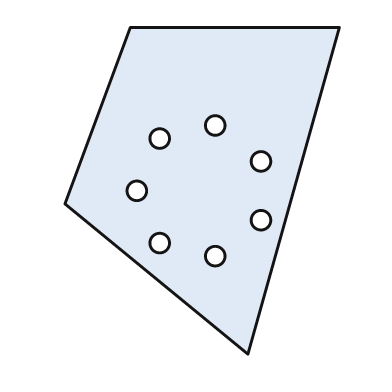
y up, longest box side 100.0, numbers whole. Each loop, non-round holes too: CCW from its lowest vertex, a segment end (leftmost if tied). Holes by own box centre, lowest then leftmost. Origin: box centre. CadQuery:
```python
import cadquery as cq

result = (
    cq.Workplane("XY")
    .moveTo(14.0, -50.0)
    .lineTo(42.0, 50.0)
    .lineTo(-22.0, 50.0)
    .lineTo(-42.0, -4.0)
    .close()
    .moveTo(4.0, -20.0)
    .circle(3.0)
    .moveTo(-13.0, -16.0)
    .circle(3.0)
    .moveTo(18.0, -9.0)
    .circle(3.0)
    .moveTo(-20.0, 0.0)
    .circle(3.0)
    .moveTo(18.0, 9.0)
    .circle(3.0)
    .moveTo(-13.0, 16.0)
    .circle(3.0)
    .moveTo(4.0, 20.0)
    .circle(3.0)
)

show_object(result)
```